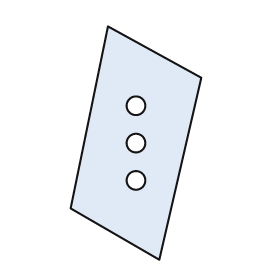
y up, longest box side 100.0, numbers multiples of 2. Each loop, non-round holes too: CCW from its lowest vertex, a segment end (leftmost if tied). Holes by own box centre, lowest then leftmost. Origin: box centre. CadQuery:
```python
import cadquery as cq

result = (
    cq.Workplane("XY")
    .moveTo(10.0, -50.0)
    .lineTo(28.0, 28.0)
    .lineTo(-12.0, 50.0)
    .lineTo(-28.0, -28.0)
    .close()
    .moveTo(0.0, -16.0)
    .circle(4.0)
    .moveTo(0.0, 0.0)
    .circle(4.0)
    .moveTo(0.0, 16.0)
    .circle(4.0)
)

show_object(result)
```